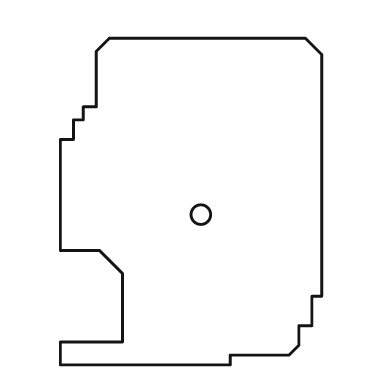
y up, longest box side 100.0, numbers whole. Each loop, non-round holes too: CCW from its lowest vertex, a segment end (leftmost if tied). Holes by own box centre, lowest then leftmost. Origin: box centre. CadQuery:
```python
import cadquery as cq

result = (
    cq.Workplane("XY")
    .moveTo(-40.0, -50.0)
    .lineTo(12.0, -50.0)
    .lineTo(12.0, -47.0)
    .lineTo(30.0, -47.0)
    .lineTo(33.0, -44.0)
    .lineTo(33.0, -38.0)
    .lineTo(37.0, -38.0)
    .lineTo(37.0, -29.0)
    .lineTo(40.0, -29.0)
    .lineTo(40.0, 45.0)
    .lineTo(35.0, 50.0)
    .lineTo(-25.0, 50.0)
    .lineTo(-29.0, 46.0)
    .lineTo(-29.0, 29.0)
    .lineTo(-33.0, 29.0)
    .lineTo(-33.0, 25.0)
    .lineTo(-36.0, 25.0)
    .lineTo(-36.0, 19.0)
    .lineTo(-40.0, 19.0)
    .lineTo(-40.0, -15.0)
    .lineTo(-28.0, -15.0)
    .lineTo(-21.0, -22.0)
    .lineTo(-21.0, -43.0)
    .lineTo(-40.0, -43.0)
    .close()
    .moveTo(3.0, -4.0)
    .circle(3.0)
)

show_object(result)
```